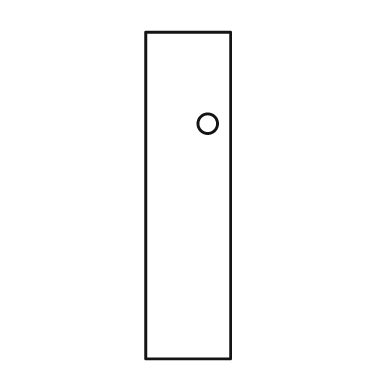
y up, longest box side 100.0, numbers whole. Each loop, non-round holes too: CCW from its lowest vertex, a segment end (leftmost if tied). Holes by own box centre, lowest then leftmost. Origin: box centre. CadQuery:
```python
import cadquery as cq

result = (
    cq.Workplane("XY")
    .moveTo(-13.0, -50.0)
    .lineTo(13.0, -50.0)
    .lineTo(13.0, 50.0)
    .lineTo(-13.0, 50.0)
    .close()
    .moveTo(6.0, 22.0)
    .circle(3.0)
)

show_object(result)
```